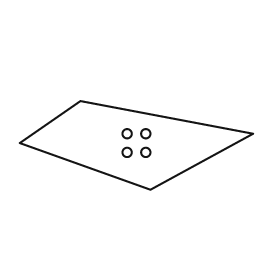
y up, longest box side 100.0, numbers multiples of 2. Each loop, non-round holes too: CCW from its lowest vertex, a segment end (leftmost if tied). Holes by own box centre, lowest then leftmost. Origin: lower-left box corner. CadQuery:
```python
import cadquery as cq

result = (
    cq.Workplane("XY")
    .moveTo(56.0, 0.0)
    .lineTo(100.0, 24.0)
    .lineTo(26.0, 38.0)
    .lineTo(0.0, 20.0)
    .close()
    .moveTo(46.0, 16.0)
    .circle(2.0)
    .moveTo(54.0, 16.0)
    .circle(2.0)
    .moveTo(46.0, 24.0)
    .circle(2.0)
    .moveTo(54.0, 24.0)
    .circle(2.0)
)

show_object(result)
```